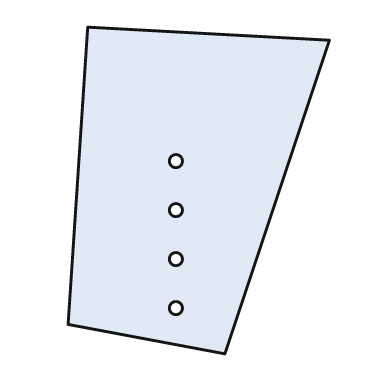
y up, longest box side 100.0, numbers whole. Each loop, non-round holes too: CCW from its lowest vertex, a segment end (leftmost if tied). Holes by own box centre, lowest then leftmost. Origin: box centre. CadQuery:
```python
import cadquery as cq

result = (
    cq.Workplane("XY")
    .moveTo(8.0, -50.0)
    .lineTo(40.0, 46.0)
    .lineTo(-34.0, 50.0)
    .lineTo(-40.0, -41.0)
    .close()
    .moveTo(-7.0, -36.0)
    .circle(2.0)
    .moveTo(-7.0, -21.0)
    .circle(2.0)
    .moveTo(-7.0, -6.0)
    .circle(2.0)
    .moveTo(-7.0, 9.0)
    .circle(2.0)
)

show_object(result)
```